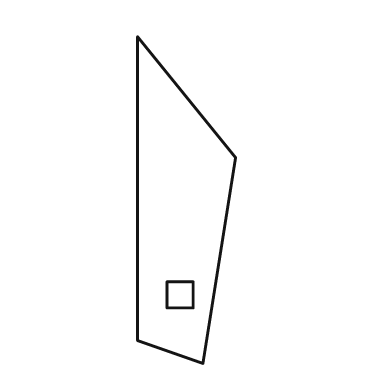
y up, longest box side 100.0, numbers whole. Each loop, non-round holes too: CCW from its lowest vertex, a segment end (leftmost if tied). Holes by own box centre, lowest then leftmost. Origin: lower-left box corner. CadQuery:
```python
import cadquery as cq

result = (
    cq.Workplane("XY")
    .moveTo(20.0, 0.0)
    .lineTo(30.0, 63.0)
    .lineTo(0.0, 100.0)
    .lineTo(0.0, 7.0)
    .close()
    .moveTo(9.0, 17.0)
    .lineTo(17.0, 17.0)
    .lineTo(17.0, 25.0)
    .lineTo(9.0, 25.0)
    .close()
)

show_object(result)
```